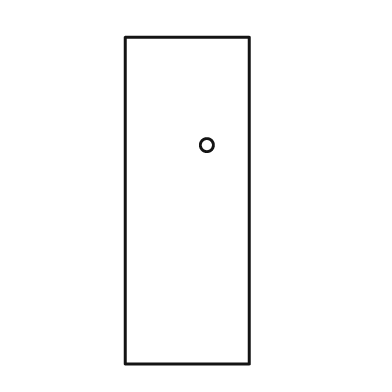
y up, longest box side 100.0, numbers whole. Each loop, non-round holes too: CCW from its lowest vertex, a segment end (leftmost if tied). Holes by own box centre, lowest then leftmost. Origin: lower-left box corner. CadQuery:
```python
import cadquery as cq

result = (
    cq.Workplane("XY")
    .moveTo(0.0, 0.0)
    .lineTo(38.0, 0.0)
    .lineTo(38.0, 100.0)
    .lineTo(0.0, 100.0)
    .close()
    .moveTo(25.0, 67.0)
    .circle(2.0)
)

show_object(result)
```